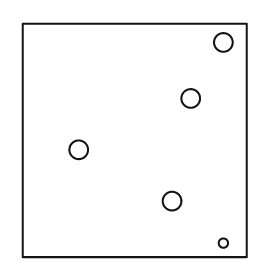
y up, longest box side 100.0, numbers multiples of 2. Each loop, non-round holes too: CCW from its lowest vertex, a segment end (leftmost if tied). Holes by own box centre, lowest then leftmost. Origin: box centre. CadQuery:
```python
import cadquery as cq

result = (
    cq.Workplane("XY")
    .moveTo(-48.0, -50.0)
    .lineTo(48.0, -50.0)
    .lineTo(48.0, 50.0)
    .lineTo(-48.0, 50.0)
    .close()
    .moveTo(38.0, -44.0)
    .circle(2.0)
    .moveTo(16.0, -26.0)
    .circle(4.0)
    .moveTo(-24.0, -4.0)
    .circle(4.0)
    .moveTo(24.0, 18.0)
    .circle(4.0)
    .moveTo(38.0, 42.0)
    .circle(4.0)
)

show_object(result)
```